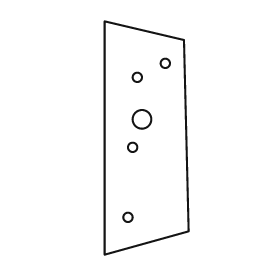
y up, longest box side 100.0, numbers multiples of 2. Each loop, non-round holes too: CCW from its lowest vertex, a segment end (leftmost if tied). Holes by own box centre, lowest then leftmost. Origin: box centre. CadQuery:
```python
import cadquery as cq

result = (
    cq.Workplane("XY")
    .moveTo(-18.0, -50.0)
    .lineTo(18.0, -40.0)
    .lineTo(16.0, 42.0)
    .lineTo(-18.0, 50.0)
    .close()
    .moveTo(-8.0, -34.0)
    .circle(2.0)
    .moveTo(-6.0, -4.0)
    .circle(2.0)
    .moveTo(-2.0, 8.0)
    .circle(4.0)
    .moveTo(-4.0, 26.0)
    .circle(2.0)
    .moveTo(8.0, 32.0)
    .circle(2.0)
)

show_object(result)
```